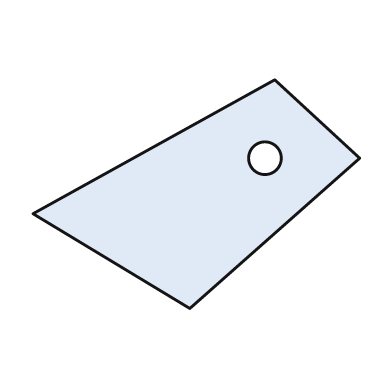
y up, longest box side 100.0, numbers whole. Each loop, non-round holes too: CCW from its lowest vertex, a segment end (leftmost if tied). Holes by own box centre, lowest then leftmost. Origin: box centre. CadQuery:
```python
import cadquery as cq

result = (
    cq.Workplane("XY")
    .moveTo(-2.0, -35.0)
    .lineTo(50.0, 11.0)
    .lineTo(24.0, 35.0)
    .lineTo(-50.0, -6.0)
    .close()
    .moveTo(21.0, 11.0)
    .circle(5.0)
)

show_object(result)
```